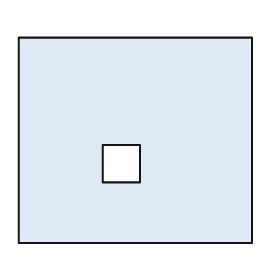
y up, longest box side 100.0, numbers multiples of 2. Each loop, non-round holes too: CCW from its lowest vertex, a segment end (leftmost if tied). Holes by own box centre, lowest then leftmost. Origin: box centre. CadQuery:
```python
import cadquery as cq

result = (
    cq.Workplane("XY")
    .moveTo(-50.0, -44.0)
    .lineTo(50.0, -44.0)
    .lineTo(50.0, 44.0)
    .lineTo(-50.0, 44.0)
    .close()
    .moveTo(-14.0, -18.0)
    .lineTo(2.0, -18.0)
    .lineTo(2.0, -2.0)
    .lineTo(-14.0, -2.0)
    .close()
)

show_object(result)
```